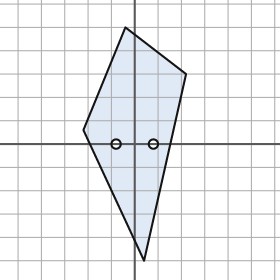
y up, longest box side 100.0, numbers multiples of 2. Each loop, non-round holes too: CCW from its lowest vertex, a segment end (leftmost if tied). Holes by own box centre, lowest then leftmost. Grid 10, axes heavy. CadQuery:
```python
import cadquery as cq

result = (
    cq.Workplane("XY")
    .moveTo(4.0, -50.0)
    .lineTo(22.0, 30.0)
    .lineTo(-4.0, 50.0)
    .lineTo(-22.0, 6.0)
    .close()
    .moveTo(-8.0, 0.0)
    .circle(2.0)
    .moveTo(8.0, 0.0)
    .circle(2.0)
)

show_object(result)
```